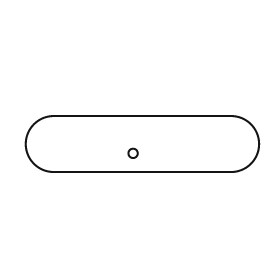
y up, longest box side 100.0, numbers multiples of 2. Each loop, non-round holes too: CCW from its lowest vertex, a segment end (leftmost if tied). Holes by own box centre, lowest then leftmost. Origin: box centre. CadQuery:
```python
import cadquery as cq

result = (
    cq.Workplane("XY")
    .moveTo(-38.0, -12.0)
    .lineTo(38.0, -12.0)
    .threePointArc((50.0, 0.0), (38.0, 12.0))
    .lineTo(-38.0, 12.0)
    .threePointArc((-50.0, 0.0), (-38.0, -12.0))
    .close()
    .moveTo(-4.0, -4.0)
    .circle(2.0)
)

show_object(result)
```